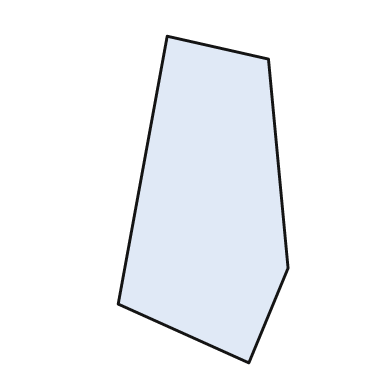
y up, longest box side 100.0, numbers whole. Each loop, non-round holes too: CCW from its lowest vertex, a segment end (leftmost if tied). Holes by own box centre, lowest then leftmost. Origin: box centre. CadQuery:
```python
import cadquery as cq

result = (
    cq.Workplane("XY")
    .moveTo(14.0, -50.0)
    .lineTo(26.0, -21.0)
    .lineTo(20.0, 43.0)
    .lineTo(-11.0, 50.0)
    .lineTo(-26.0, -32.0)
    .close()
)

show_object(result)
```